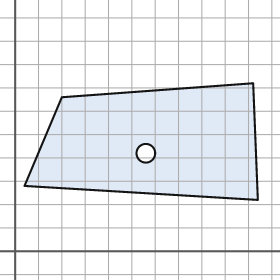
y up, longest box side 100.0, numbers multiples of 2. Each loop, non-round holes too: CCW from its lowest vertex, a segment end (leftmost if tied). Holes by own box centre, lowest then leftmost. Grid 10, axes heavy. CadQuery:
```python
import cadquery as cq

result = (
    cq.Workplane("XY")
    .moveTo(104.0, 22.0)
    .lineTo(102.0, 72.0)
    .lineTo(20.0, 66.0)
    .lineTo(4.0, 28.0)
    .close()
    .moveTo(56.0, 42.0)
    .circle(4.0)
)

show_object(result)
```